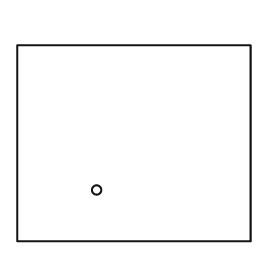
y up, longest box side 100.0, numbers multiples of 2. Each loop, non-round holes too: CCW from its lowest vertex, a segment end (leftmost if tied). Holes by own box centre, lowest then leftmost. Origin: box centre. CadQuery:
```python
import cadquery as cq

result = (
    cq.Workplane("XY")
    .moveTo(-50.0, -42.0)
    .lineTo(50.0, -42.0)
    .lineTo(50.0, 42.0)
    .lineTo(-50.0, 42.0)
    .close()
    .moveTo(-16.0, -20.0)
    .circle(2.0)
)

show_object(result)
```